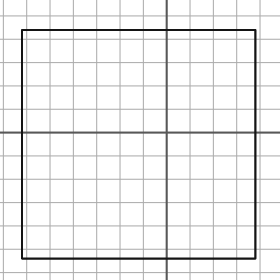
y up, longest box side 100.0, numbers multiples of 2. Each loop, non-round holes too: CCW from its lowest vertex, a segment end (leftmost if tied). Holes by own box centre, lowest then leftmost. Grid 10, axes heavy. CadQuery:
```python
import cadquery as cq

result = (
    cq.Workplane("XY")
    .moveTo(-62.0, -54.0)
    .lineTo(38.0, -54.0)
    .lineTo(38.0, 44.0)
    .lineTo(-62.0, 44.0)
    .close()
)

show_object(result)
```